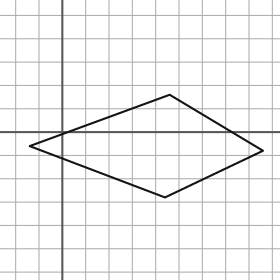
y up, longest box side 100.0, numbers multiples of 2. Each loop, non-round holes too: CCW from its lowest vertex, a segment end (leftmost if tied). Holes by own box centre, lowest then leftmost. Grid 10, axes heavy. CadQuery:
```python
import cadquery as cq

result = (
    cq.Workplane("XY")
    .moveTo(44.0, -28.0)
    .lineTo(86.0, -8.0)
    .lineTo(46.0, 16.0)
    .lineTo(-14.0, -6.0)
    .close()
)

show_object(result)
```